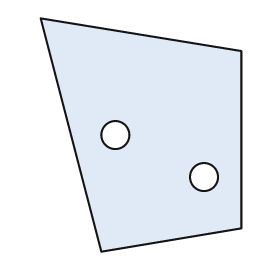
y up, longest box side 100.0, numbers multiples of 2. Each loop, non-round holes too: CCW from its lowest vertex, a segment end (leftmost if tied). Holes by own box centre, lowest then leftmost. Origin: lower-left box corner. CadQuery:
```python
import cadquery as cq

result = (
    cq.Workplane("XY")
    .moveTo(26.0, 0.0)
    .lineTo(86.0, 10.0)
    .lineTo(86.0, 86.0)
    .lineTo(0.0, 100.0)
    .close()
    .moveTo(70.0, 32.0)
    .circle(6.0)
    .moveTo(32.0, 50.0)
    .circle(6.0)
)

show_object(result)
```